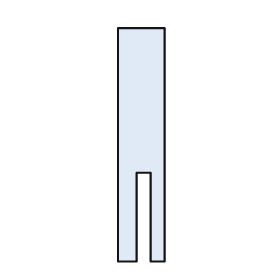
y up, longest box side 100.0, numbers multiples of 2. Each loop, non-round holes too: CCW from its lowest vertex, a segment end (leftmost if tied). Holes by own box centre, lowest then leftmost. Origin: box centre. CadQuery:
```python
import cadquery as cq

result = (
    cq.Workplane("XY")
    .moveTo(-10.0, -50.0)
    .lineTo(-2.0, -50.0)
    .lineTo(-2.0, -12.0)
    .lineTo(4.0, -12.0)
    .lineTo(4.0, -50.0)
    .lineTo(10.0, -50.0)
    .lineTo(10.0, 50.0)
    .lineTo(-10.0, 50.0)
    .close()
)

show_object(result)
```